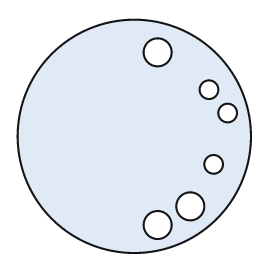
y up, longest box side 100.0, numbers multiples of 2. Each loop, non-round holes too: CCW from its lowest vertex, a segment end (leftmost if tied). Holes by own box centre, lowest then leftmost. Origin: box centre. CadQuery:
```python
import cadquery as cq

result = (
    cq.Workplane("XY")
    .moveTo(0.0, 0.0)
    .circle(50.0)
    .moveTo(10.0, -38.0)
    .circle(6.0)
    .moveTo(24.0, -30.0)
    .circle(6.0)
    .moveTo(34.0, -12.0)
    .circle(4.0)
    .moveTo(40.0, 10.0)
    .circle(4.0)
    .moveTo(32.0, 20.0)
    .circle(4.0)
    .moveTo(10.0, 36.0)
    .circle(6.0)
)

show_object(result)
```